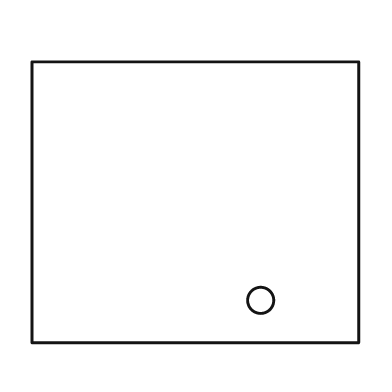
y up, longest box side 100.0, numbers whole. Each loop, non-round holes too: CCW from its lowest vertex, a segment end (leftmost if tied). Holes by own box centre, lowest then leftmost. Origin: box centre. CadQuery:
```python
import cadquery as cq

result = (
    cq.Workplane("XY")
    .moveTo(-50.0, -43.0)
    .lineTo(50.0, -43.0)
    .lineTo(50.0, 43.0)
    .lineTo(-50.0, 43.0)
    .close()
    .moveTo(20.0, -30.0)
    .circle(4.0)
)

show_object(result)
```